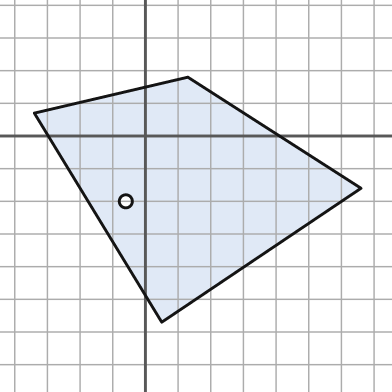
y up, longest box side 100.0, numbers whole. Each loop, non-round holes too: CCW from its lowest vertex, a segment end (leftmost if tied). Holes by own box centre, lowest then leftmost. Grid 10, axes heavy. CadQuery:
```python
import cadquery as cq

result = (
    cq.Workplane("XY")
    .moveTo(5.0, -57.0)
    .lineTo(66.0, -16.0)
    .lineTo(13.0, 18.0)
    .lineTo(-34.0, 7.0)
    .close()
    .moveTo(-6.0, -20.0)
    .circle(2.0)
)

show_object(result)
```